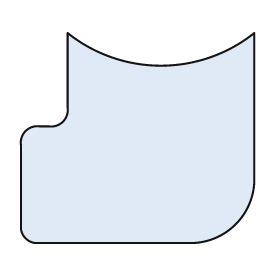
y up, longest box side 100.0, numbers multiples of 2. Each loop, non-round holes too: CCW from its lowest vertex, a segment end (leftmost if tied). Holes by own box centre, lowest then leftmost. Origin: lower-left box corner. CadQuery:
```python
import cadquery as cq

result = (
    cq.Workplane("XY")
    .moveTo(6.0, 0.0)
    .lineTo(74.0, 0.0)
    .threePointArc((92.0, 8.0), (100.0, 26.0))
    .lineTo(100.0, 90.0)
    .threePointArc((60.0, 76.0), (20.0, 90.0))
    .lineTo(20.0, 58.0)
    .threePointArc((18.0, 52.0), (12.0, 50.0))
    .lineTo(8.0, 50.0)
    .threePointArc((2.0, 48.0), (0.0, 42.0))
    .lineTo(0.0, 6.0)
    .threePointArc((2.0, 2.0), (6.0, 0.0))
    .close()
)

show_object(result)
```